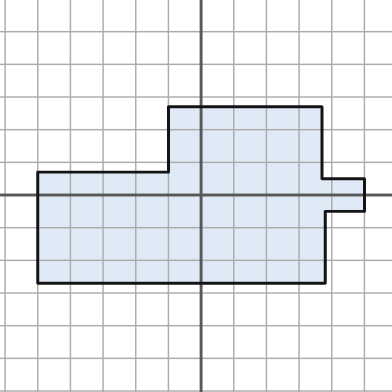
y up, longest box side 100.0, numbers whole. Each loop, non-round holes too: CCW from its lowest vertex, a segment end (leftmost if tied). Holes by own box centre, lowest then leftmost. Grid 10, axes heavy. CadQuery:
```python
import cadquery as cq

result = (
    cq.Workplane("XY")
    .moveTo(-50.0, -27.0)
    .lineTo(38.0, -27.0)
    .lineTo(38.0, -5.0)
    .lineTo(50.0, -5.0)
    .lineTo(50.0, 5.0)
    .lineTo(37.0, 5.0)
    .lineTo(37.0, 27.0)
    .lineTo(-10.0, 27.0)
    .lineTo(-10.0, 7.0)
    .lineTo(-50.0, 7.0)
    .close()
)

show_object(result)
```